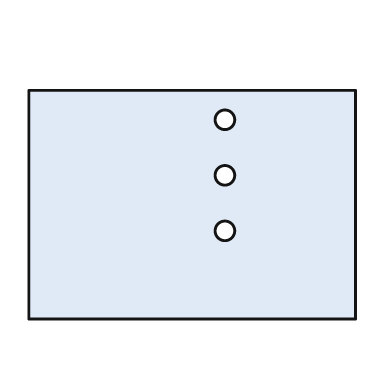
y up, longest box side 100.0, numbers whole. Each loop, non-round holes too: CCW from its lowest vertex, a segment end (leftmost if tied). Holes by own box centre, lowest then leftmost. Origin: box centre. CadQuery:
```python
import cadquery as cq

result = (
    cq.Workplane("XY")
    .moveTo(-50.0, -35.0)
    .lineTo(50.0, -35.0)
    .lineTo(50.0, 35.0)
    .lineTo(-50.0, 35.0)
    .close()
    .moveTo(10.0, -8.0)
    .circle(3.0)
    .moveTo(10.0, 9.0)
    .circle(3.0)
    .moveTo(10.0, 26.0)
    .circle(3.0)
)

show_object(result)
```